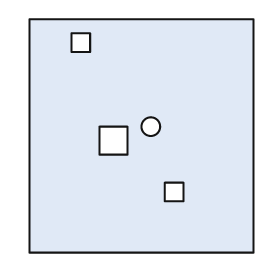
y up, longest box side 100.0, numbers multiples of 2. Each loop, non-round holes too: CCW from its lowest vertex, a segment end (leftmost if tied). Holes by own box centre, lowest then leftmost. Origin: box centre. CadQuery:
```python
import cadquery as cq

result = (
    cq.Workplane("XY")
    .moveTo(-48.0, -50.0)
    .lineTo(48.0, -50.0)
    .lineTo(48.0, 50.0)
    .lineTo(-48.0, 50.0)
    .close()
    .moveTo(10.0, -28.0)
    .lineTo(18.0, -28.0)
    .lineTo(18.0, -20.0)
    .lineTo(10.0, -20.0)
    .close()
    .moveTo(-18.0, -8.0)
    .lineTo(-6.0, -8.0)
    .lineTo(-6.0, 4.0)
    .lineTo(-18.0, 4.0)
    .close()
    .moveTo(4.0, 4.0)
    .circle(4.0)
    .moveTo(-30.0, 36.0)
    .lineTo(-22.0, 36.0)
    .lineTo(-22.0, 44.0)
    .lineTo(-30.0, 44.0)
    .close()
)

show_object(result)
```